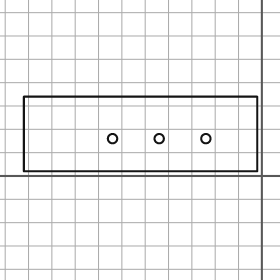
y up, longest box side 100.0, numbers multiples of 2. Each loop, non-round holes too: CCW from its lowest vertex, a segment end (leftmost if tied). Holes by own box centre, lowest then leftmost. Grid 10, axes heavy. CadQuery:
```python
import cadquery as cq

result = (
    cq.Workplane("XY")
    .moveTo(-102.0, 2.0)
    .lineTo(-2.0, 2.0)
    .lineTo(-2.0, 34.0)
    .lineTo(-102.0, 34.0)
    .close()
    .moveTo(-64.0, 16.0)
    .circle(2.0)
    .moveTo(-44.0, 16.0)
    .circle(2.0)
    .moveTo(-24.0, 16.0)
    .circle(2.0)
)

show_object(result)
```